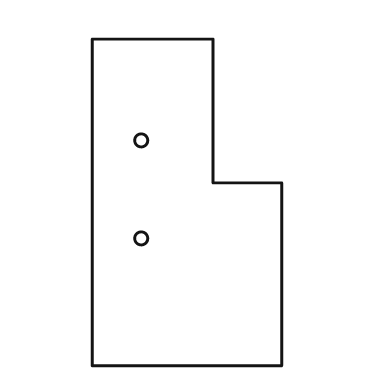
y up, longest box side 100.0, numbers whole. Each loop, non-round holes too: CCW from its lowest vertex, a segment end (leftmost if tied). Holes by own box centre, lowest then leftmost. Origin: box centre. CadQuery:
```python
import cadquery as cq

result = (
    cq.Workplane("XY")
    .moveTo(-29.0, -50.0)
    .lineTo(29.0, -50.0)
    .lineTo(29.0, 6.0)
    .lineTo(8.0, 6.0)
    .lineTo(8.0, 50.0)
    .lineTo(-29.0, 50.0)
    .close()
    .moveTo(-14.0, -11.0)
    .circle(2.0)
    .moveTo(-14.0, 19.0)
    .circle(2.0)
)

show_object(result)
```